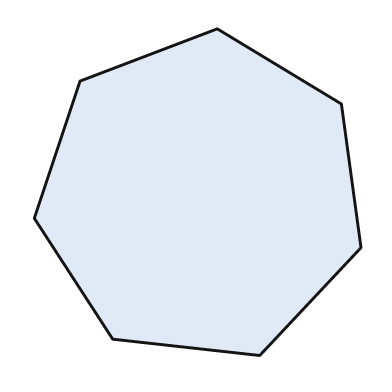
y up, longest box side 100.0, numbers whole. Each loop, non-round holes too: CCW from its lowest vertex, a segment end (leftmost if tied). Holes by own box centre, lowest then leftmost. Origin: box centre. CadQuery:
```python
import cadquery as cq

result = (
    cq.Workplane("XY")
    .moveTo(19.0, -50.0)
    .lineTo(50.0, -17.0)
    .lineTo(44.0, 27.0)
    .lineTo(6.0, 50.0)
    .lineTo(-36.0, 34.0)
    .lineTo(-50.0, -8.0)
    .lineTo(-26.0, -45.0)
    .close()
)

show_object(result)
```